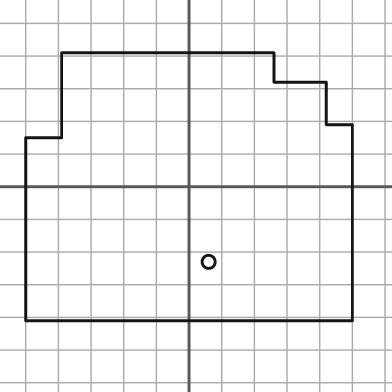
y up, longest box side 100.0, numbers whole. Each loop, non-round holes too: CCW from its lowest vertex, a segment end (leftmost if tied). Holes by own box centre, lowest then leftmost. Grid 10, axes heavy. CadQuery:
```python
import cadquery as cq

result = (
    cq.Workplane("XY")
    .moveTo(-50.0, -41.0)
    .lineTo(50.0, -41.0)
    .lineTo(50.0, 19.0)
    .lineTo(42.0, 19.0)
    .lineTo(42.0, 32.0)
    .lineTo(26.0, 32.0)
    .lineTo(26.0, 41.0)
    .lineTo(-39.0, 41.0)
    .lineTo(-39.0, 15.0)
    .lineTo(-50.0, 15.0)
    .close()
    .moveTo(6.0, -23.0)
    .circle(2.0)
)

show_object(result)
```